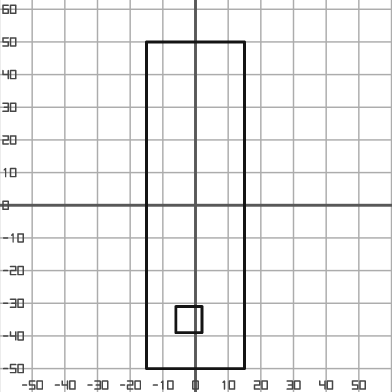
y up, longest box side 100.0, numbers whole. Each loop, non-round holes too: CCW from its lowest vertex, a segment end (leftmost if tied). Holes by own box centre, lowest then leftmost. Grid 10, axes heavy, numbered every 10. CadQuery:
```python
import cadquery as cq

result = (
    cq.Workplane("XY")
    .moveTo(-15.0, -50.0)
    .lineTo(15.0, -50.0)
    .lineTo(15.0, 50.0)
    .lineTo(-15.0, 50.0)
    .close()
    .moveTo(-6.0, -39.0)
    .lineTo(2.0, -39.0)
    .lineTo(2.0, -31.0)
    .lineTo(-6.0, -31.0)
    .close()
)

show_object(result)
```